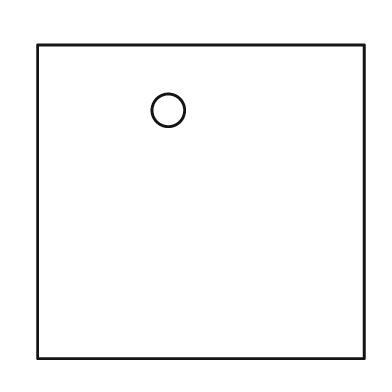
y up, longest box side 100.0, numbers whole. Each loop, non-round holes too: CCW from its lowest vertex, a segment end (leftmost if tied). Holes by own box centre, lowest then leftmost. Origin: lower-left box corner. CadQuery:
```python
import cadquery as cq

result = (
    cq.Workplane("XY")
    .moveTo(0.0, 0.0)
    .lineTo(100.0, 0.0)
    .lineTo(100.0, 96.0)
    .lineTo(0.0, 96.0)
    .close()
    .moveTo(40.0, 76.0)
    .circle(5.0)
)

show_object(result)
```